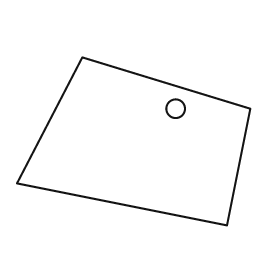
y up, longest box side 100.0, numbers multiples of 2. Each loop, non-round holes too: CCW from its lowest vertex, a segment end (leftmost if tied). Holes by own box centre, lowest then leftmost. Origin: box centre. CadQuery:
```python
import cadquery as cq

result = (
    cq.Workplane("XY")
    .moveTo(40.0, -36.0)
    .lineTo(50.0, 14.0)
    .lineTo(-22.0, 36.0)
    .lineTo(-50.0, -18.0)
    .close()
    .moveTo(18.0, 14.0)
    .circle(4.0)
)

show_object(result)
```